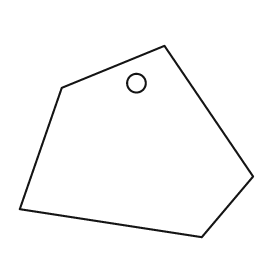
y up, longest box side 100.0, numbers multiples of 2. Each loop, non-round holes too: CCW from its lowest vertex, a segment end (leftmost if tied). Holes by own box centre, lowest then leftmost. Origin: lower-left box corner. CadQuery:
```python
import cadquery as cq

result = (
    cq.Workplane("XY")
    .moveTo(78.0, 0.0)
    .lineTo(100.0, 26.0)
    .lineTo(62.0, 82.0)
    .lineTo(18.0, 64.0)
    .lineTo(0.0, 12.0)
    .close()
    .moveTo(50.0, 66.0)
    .circle(4.0)
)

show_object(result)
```